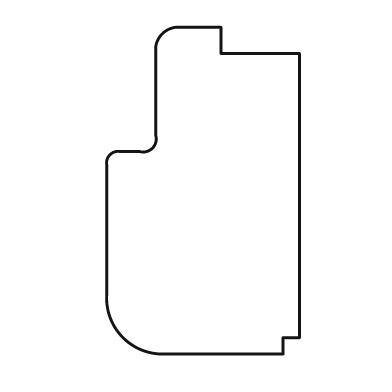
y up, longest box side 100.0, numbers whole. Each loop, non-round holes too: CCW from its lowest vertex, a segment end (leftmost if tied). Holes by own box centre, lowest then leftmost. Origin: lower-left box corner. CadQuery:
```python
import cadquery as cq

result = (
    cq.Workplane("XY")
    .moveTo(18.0, 0.0)
    .lineTo(54.0, 0.0)
    .lineTo(54.0, 5.0)
    .lineTo(59.0, 5.0)
    .lineTo(59.0, 92.0)
    .lineTo(35.0, 92.0)
    .lineTo(35.0, 100.0)
    .lineTo(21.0, 100.0)
    .threePointArc((17.0, 98.0), (15.0, 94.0))
    .lineTo(15.0, 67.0)
    .threePointArc((14.0, 63.0), (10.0, 62.0))
    .lineTo(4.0, 62.0)
    .threePointArc((1.0, 61.0), (0.0, 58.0))
    .lineTo(0.0, 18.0)
    .threePointArc((5.0, 5.0), (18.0, 0.0))
    .close()
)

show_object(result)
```